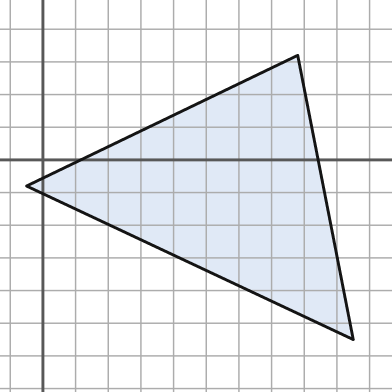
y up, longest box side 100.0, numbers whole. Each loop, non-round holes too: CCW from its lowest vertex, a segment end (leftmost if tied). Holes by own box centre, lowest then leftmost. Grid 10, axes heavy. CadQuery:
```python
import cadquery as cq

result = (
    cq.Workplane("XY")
    .moveTo(95.0, -55.0)
    .lineTo(78.0, 32.0)
    .lineTo(-5.0, -8.0)
    .close()
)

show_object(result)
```